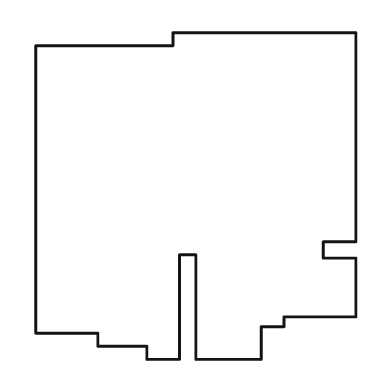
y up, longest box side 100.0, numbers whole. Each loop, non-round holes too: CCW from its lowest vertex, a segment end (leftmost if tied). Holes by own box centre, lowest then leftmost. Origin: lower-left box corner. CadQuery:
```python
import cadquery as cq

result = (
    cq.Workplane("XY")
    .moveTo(34.0, 0.0)
    .lineTo(44.0, 0.0)
    .lineTo(44.0, 32.0)
    .lineTo(49.0, 32.0)
    .lineTo(49.0, 0.0)
    .lineTo(69.0, 0.0)
    .lineTo(69.0, 10.0)
    .lineTo(76.0, 10.0)
    .lineTo(76.0, 13.0)
    .lineTo(98.0, 13.0)
    .lineTo(98.0, 31.0)
    .lineTo(88.0, 31.0)
    .lineTo(88.0, 36.0)
    .lineTo(98.0, 36.0)
    .lineTo(98.0, 100.0)
    .lineTo(42.0, 100.0)
    .lineTo(42.0, 96.0)
    .lineTo(0.0, 96.0)
    .lineTo(0.0, 8.0)
    .lineTo(19.0, 8.0)
    .lineTo(19.0, 4.0)
    .lineTo(34.0, 4.0)
    .close()
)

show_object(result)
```